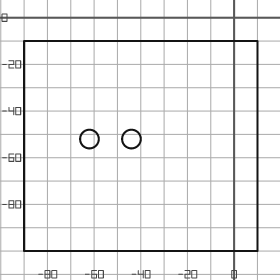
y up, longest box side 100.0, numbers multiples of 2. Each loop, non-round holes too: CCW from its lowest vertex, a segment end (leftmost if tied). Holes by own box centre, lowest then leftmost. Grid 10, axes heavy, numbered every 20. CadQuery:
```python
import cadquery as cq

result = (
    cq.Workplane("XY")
    .moveTo(-90.0, -100.0)
    .lineTo(10.0, -100.0)
    .lineTo(10.0, -10.0)
    .lineTo(-90.0, -10.0)
    .close()
    .moveTo(-62.0, -52.0)
    .circle(4.0)
    .moveTo(-44.0, -52.0)
    .circle(4.0)
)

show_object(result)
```